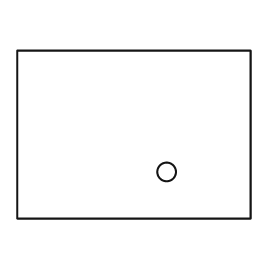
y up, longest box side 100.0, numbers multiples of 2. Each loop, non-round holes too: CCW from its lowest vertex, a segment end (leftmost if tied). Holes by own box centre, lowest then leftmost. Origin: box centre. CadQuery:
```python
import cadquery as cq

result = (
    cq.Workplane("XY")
    .moveTo(-50.0, -36.0)
    .lineTo(50.0, -36.0)
    .lineTo(50.0, 36.0)
    .lineTo(-50.0, 36.0)
    .close()
    .moveTo(14.0, -16.0)
    .circle(4.0)
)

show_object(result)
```